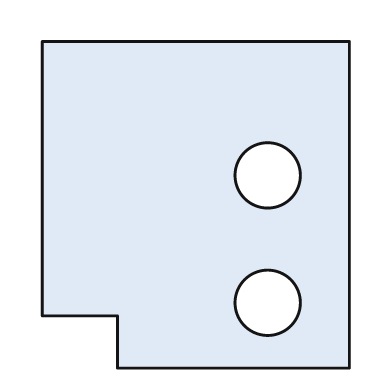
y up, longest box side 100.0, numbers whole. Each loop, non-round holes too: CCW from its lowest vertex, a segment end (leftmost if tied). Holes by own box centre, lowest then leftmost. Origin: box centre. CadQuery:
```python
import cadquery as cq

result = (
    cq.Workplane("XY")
    .moveTo(-24.0, -50.0)
    .lineTo(47.0, -50.0)
    .lineTo(47.0, 50.0)
    .lineTo(-47.0, 50.0)
    .lineTo(-47.0, -34.0)
    .lineTo(-24.0, -34.0)
    .close()
    .moveTo(22.0, -30.0)
    .circle(10.0)
    .moveTo(22.0, 9.0)
    .circle(10.0)
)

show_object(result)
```